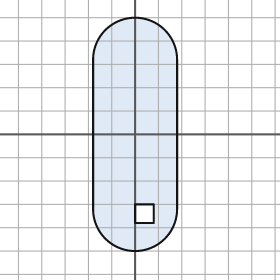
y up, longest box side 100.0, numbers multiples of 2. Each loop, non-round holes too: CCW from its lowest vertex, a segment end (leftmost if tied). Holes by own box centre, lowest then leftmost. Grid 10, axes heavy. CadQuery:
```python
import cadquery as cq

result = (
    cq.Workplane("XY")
    .moveTo(-18.0, -32.0)
    .threePointArc((0.0, -50.0), (18.0, -32.0))
    .lineTo(18.0, 32.0)
    .threePointArc((0.0, 50.0), (-18.0, 32.0))
    .close()
    .moveTo(0.0, -38.0)
    .lineTo(8.0, -38.0)
    .lineTo(8.0, -30.0)
    .lineTo(0.0, -30.0)
    .close()
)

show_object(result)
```